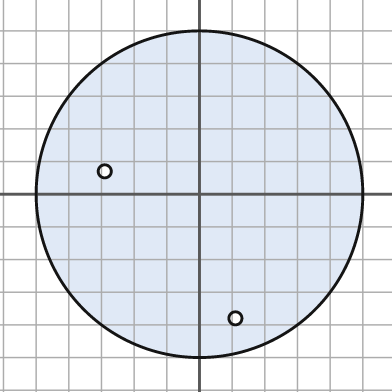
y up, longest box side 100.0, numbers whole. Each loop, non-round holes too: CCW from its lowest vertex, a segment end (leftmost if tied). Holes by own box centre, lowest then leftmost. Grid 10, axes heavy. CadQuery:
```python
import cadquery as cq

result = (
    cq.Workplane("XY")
    .moveTo(0.0, 0.0)
    .circle(50.0)
    .moveTo(11.0, -38.0)
    .circle(2.0)
    .moveTo(-29.0, 7.0)
    .circle(2.0)
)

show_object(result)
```